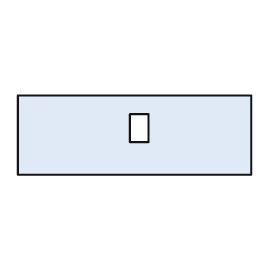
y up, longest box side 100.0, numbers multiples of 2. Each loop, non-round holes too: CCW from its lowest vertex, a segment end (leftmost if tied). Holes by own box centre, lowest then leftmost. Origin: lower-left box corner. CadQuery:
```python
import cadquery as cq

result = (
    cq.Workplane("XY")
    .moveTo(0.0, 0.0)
    .lineTo(100.0, 0.0)
    .lineTo(100.0, 34.0)
    .lineTo(0.0, 34.0)
    .close()
    .moveTo(48.0, 14.0)
    .lineTo(56.0, 14.0)
    .lineTo(56.0, 26.0)
    .lineTo(48.0, 26.0)
    .close()
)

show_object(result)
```